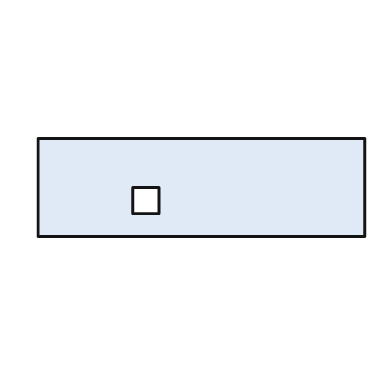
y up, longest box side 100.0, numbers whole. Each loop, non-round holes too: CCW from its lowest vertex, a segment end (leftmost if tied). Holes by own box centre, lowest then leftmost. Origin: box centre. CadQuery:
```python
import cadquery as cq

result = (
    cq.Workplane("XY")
    .moveTo(-50.0, -15.0)
    .lineTo(50.0, -15.0)
    .lineTo(50.0, 15.0)
    .lineTo(-50.0, 15.0)
    .close()
    .moveTo(-21.0, -8.0)
    .lineTo(-13.0, -8.0)
    .lineTo(-13.0, 0.0)
    .lineTo(-21.0, 0.0)
    .close()
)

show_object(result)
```